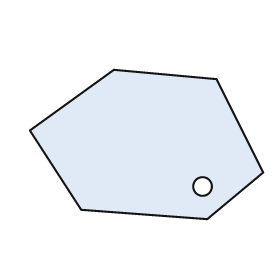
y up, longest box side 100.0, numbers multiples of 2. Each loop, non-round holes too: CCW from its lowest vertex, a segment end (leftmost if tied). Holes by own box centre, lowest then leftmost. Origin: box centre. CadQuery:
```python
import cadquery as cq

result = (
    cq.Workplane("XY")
    .moveTo(26.0, -32.0)
    .lineTo(50.0, -12.0)
    .lineTo(30.0, 28.0)
    .lineTo(-14.0, 32.0)
    .lineTo(-50.0, 6.0)
    .lineTo(-28.0, -28.0)
    .close()
    .moveTo(24.0, -18.0)
    .circle(4.0)
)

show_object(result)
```